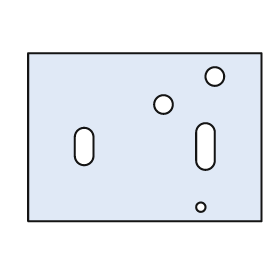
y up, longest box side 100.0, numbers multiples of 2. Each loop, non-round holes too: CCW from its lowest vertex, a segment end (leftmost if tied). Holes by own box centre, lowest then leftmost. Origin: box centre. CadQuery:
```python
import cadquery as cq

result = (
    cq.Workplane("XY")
    .moveTo(-50.0, -36.0)
    .lineTo(50.0, -36.0)
    .lineTo(50.0, 36.0)
    .lineTo(-50.0, 36.0)
    .close()
    .moveTo(24.0, -30.0)
    .circle(2.0)
    .moveTo(-30.0, -8.0)
    .threePointArc((-26.0, -12.0), (-22.0, -8.0))
    .lineTo(-22.0, 0.0)
    .threePointArc((-26.0, 4.0), (-30.0, 0.0))
    .close()
    .moveTo(22.0, -10.0)
    .threePointArc((26.0, -14.0), (30.0, -10.0))
    .lineTo(30.0, 2.0)
    .threePointArc((26.0, 6.0), (22.0, 2.0))
    .close()
    .moveTo(8.0, 14.0)
    .circle(4.0)
    .moveTo(30.0, 26.0)
    .circle(4.0)
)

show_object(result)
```